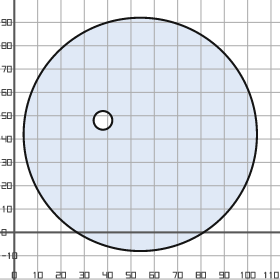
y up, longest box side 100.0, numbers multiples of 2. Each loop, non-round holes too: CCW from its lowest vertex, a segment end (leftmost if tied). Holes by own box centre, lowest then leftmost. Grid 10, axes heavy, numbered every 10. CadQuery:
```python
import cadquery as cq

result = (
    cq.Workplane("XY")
    .moveTo(54.0, 42.0)
    .circle(50.0)
    .moveTo(38.0, 48.0)
    .circle(4.0)
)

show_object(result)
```